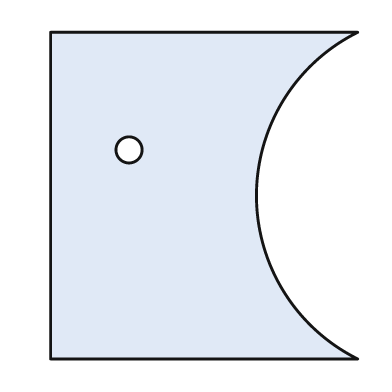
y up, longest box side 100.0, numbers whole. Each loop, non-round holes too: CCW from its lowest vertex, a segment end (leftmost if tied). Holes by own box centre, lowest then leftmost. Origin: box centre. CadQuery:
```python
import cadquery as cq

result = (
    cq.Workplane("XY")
    .moveTo(-47.0, -50.0)
    .lineTo(47.0, -50.0)
    .threePointArc((16.0, 0.0), (47.0, 50.0))
    .lineTo(-47.0, 50.0)
    .close()
    .moveTo(-23.0, 14.0)
    .circle(4.0)
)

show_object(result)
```